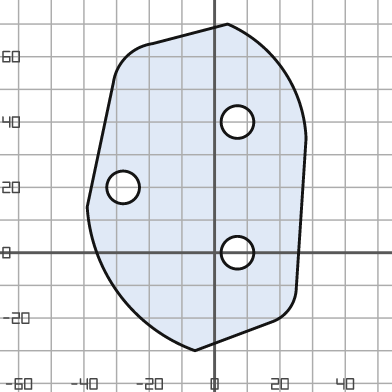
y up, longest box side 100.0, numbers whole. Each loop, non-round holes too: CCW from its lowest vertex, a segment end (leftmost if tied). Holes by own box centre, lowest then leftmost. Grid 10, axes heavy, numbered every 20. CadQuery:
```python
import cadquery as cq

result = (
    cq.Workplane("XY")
    .moveTo(-6.0, -30.0)
    .lineTo(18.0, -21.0)
    .threePointArc((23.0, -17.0), (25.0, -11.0))
    .lineTo(28.0, 35.0)
    .threePointArc((21.0, 56.0), (4.0, 70.0))
    .lineTo(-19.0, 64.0)
    .threePointArc((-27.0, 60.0), (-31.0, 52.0))
    .lineTo(-39.0, 14.0)
    .threePointArc((-29.0, -13.0), (-6.0, -30.0))
    .close()
    .moveTo(7.0, 0.0)
    .circle(5.0)
    .moveTo(-28.0, 20.0)
    .circle(5.0)
    .moveTo(7.0, 40.0)
    .circle(5.0)
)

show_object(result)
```